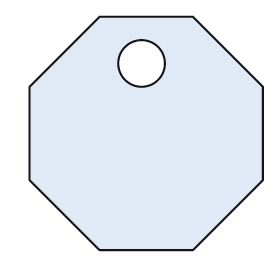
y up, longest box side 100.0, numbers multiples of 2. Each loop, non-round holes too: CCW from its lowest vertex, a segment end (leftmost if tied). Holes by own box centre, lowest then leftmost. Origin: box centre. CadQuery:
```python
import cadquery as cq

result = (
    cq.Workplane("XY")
    .moveTo(-20.0, -50.0)
    .lineTo(20.0, -50.0)
    .lineTo(50.0, -20.0)
    .lineTo(50.0, 20.0)
    .lineTo(20.0, 50.0)
    .lineTo(-20.0, 50.0)
    .lineTo(-50.0, 20.0)
    .lineTo(-50.0, -20.0)
    .close()
    .moveTo(-2.0, 30.0)
    .circle(10.0)
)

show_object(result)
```